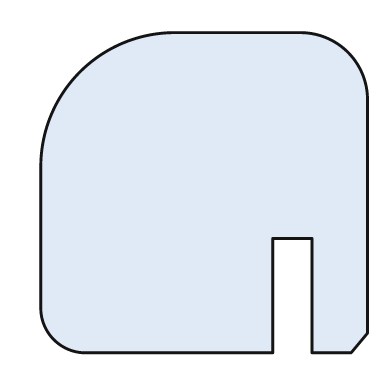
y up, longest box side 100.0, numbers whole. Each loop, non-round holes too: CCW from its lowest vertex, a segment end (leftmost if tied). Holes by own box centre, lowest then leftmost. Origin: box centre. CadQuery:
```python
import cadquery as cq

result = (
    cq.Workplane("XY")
    .moveTo(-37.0, -49.0)
    .lineTo(21.0, -49.0)
    .lineTo(21.0, -14.0)
    .lineTo(33.0, -14.0)
    .lineTo(33.0, -49.0)
    .lineTo(45.0, -49.0)
    .lineTo(50.0, -43.0)
    .lineTo(50.0, 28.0)
    .threePointArc((44.0, 43.0), (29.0, 49.0))
    .lineTo(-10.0, 49.0)
    .threePointArc((-38.0, 37.0), (-50.0, 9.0))
    .lineTo(-50.0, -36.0)
    .threePointArc((-46.0, -45.0), (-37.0, -49.0))
    .close()
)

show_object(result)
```